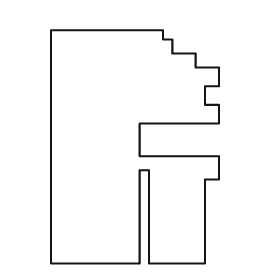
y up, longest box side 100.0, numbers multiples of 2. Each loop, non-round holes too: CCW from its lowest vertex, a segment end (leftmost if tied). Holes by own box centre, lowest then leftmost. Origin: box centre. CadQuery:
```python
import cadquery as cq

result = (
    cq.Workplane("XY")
    .moveTo(-36.0, -50.0)
    .lineTo(2.0, -50.0)
    .lineTo(2.0, -10.0)
    .lineTo(6.0, -10.0)
    .lineTo(6.0, -50.0)
    .lineTo(30.0, -50.0)
    .lineTo(30.0, -14.0)
    .lineTo(36.0, -14.0)
    .lineTo(36.0, -4.0)
    .lineTo(2.0, -4.0)
    .lineTo(2.0, 10.0)
    .lineTo(36.0, 10.0)
    .lineTo(36.0, 18.0)
    .lineTo(30.0, 18.0)
    .lineTo(30.0, 26.0)
    .lineTo(36.0, 26.0)
    .lineTo(36.0, 34.0)
    .lineTo(26.0, 34.0)
    .lineTo(26.0, 40.0)
    .lineTo(16.0, 40.0)
    .lineTo(16.0, 46.0)
    .lineTo(12.0, 46.0)
    .lineTo(12.0, 50.0)
    .lineTo(-36.0, 50.0)
    .close()
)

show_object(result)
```